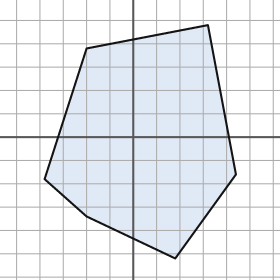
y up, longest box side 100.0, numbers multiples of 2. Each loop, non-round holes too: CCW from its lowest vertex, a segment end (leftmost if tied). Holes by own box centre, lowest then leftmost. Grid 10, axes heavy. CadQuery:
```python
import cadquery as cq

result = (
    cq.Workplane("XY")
    .moveTo(18.0, -52.0)
    .lineTo(44.0, -16.0)
    .lineTo(32.0, 48.0)
    .lineTo(-20.0, 38.0)
    .lineTo(-38.0, -18.0)
    .lineTo(-20.0, -34.0)
    .close()
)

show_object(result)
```